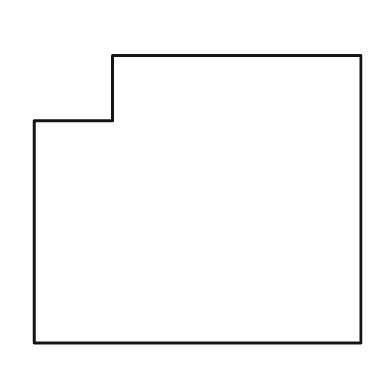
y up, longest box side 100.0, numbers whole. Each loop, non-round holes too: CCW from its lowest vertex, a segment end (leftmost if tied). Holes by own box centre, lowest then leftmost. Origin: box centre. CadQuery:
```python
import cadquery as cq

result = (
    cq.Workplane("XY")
    .moveTo(-50.0, -44.0)
    .lineTo(50.0, -44.0)
    .lineTo(50.0, 44.0)
    .lineTo(-26.0, 44.0)
    .lineTo(-26.0, 24.0)
    .lineTo(-50.0, 24.0)
    .close()
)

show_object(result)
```